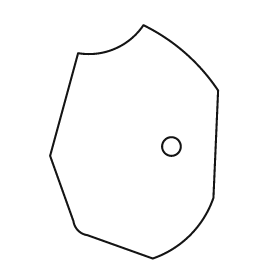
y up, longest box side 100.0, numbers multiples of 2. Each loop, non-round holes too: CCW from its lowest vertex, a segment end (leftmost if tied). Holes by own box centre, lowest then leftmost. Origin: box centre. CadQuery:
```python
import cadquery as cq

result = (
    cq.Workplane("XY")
    .moveTo(8.0, -50.0)
    .threePointArc((24.0, -40.0), (34.0, -24.0))
    .lineTo(36.0, 22.0)
    .threePointArc((22.0, 38.0), (4.0, 50.0))
    .threePointArc((-8.0, 40.0), (-24.0, 38.0))
    .lineTo(-36.0, -6.0)
    .lineTo(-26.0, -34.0)
    .threePointArc((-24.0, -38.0), (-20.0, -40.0))
    .close()
    .moveTo(16.0, -2.0)
    .circle(4.0)
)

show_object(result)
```